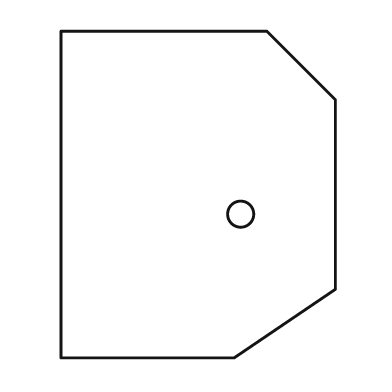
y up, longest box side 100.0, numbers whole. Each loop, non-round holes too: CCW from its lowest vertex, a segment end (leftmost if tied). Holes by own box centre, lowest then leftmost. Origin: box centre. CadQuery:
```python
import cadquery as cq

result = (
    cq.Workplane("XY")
    .moveTo(-42.0, -50.0)
    .lineTo(11.0, -50.0)
    .lineTo(42.0, -29.0)
    .lineTo(42.0, 29.0)
    .lineTo(21.0, 50.0)
    .lineTo(-42.0, 50.0)
    .close()
    .moveTo(13.0, -6.0)
    .circle(4.0)
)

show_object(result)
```